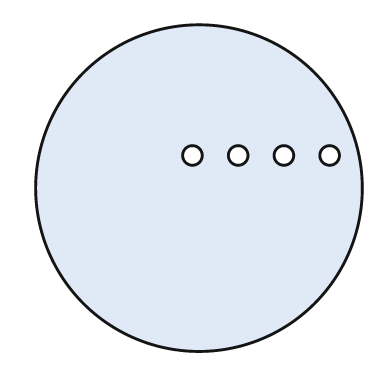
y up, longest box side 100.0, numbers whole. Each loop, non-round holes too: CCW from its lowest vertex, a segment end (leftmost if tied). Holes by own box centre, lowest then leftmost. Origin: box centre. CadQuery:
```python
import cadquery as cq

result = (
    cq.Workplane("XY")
    .moveTo(0.0, 0.0)
    .circle(50.0)
    .moveTo(-2.0, 10.0)
    .circle(3.0)
    .moveTo(12.0, 10.0)
    .circle(3.0)
    .moveTo(26.0, 10.0)
    .circle(3.0)
    .moveTo(40.0, 10.0)
    .circle(3.0)
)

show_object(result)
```